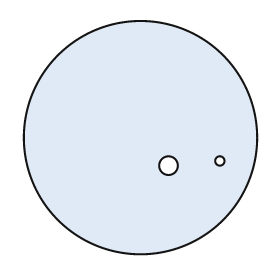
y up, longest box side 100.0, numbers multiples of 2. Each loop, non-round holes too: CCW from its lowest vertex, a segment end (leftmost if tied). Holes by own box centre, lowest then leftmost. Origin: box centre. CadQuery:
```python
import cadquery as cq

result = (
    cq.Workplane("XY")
    .moveTo(0.0, 0.0)
    .circle(50.0)
    .moveTo(12.0, -12.0)
    .circle(4.0)
    .moveTo(34.0, -10.0)
    .circle(2.0)
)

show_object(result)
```